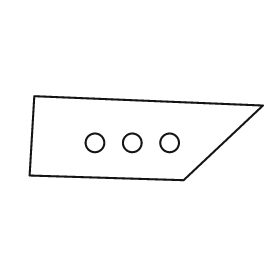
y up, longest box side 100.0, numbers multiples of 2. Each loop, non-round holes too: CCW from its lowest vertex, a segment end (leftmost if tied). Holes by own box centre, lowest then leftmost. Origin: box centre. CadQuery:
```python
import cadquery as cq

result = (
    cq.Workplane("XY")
    .moveTo(16.0, -18.0)
    .lineTo(50.0, 14.0)
    .lineTo(-48.0, 18.0)
    .lineTo(-50.0, -16.0)
    .close()
    .moveTo(-22.0, -2.0)
    .circle(4.0)
    .moveTo(-6.0, -2.0)
    .circle(4.0)
    .moveTo(10.0, -2.0)
    .circle(4.0)
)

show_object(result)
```